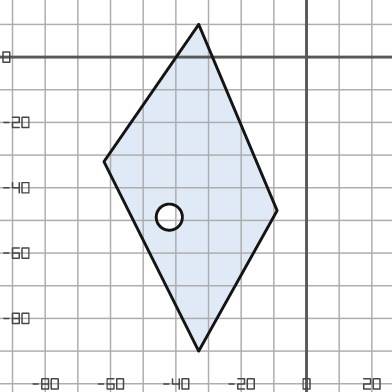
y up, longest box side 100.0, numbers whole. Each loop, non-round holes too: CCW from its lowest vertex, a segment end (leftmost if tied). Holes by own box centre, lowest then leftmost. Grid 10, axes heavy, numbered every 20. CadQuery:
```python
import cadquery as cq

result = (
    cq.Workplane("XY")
    .moveTo(-33.0, -90.0)
    .lineTo(-9.0, -47.0)
    .lineTo(-33.0, 10.0)
    .lineTo(-62.0, -32.0)
    .close()
    .moveTo(-42.0, -49.0)
    .circle(4.0)
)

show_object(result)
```